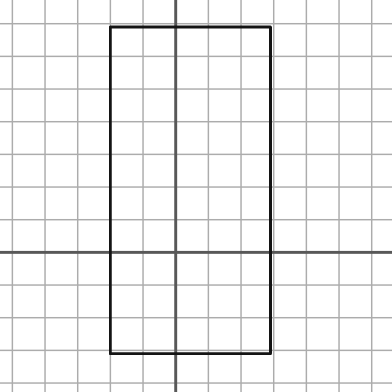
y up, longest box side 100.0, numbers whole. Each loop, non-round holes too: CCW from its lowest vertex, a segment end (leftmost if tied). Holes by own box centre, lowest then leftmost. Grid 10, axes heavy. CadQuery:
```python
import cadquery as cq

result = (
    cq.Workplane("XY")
    .moveTo(-20.0, -31.0)
    .lineTo(29.0, -31.0)
    .lineTo(29.0, 69.0)
    .lineTo(-20.0, 69.0)
    .close()
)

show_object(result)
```